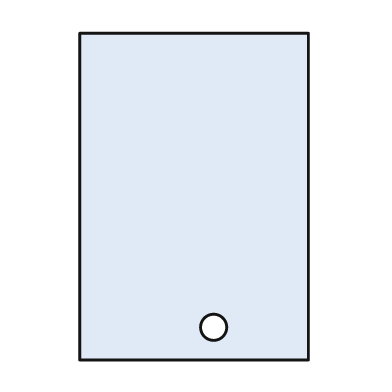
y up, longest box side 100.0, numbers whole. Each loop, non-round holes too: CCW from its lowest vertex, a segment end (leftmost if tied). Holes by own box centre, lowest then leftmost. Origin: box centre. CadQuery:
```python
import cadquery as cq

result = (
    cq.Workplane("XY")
    .moveTo(-35.0, -50.0)
    .lineTo(35.0, -50.0)
    .lineTo(35.0, 50.0)
    .lineTo(-35.0, 50.0)
    .close()
    .moveTo(6.0, -40.0)
    .circle(4.0)
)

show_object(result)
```